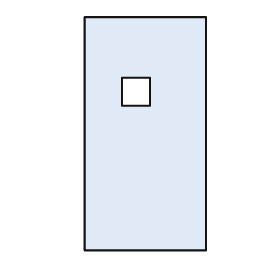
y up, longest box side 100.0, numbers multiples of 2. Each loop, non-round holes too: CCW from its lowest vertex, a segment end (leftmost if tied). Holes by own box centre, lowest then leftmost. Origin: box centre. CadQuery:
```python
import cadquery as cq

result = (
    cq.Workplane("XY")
    .moveTo(-26.0, -50.0)
    .lineTo(26.0, -50.0)
    .lineTo(26.0, 50.0)
    .lineTo(-26.0, 50.0)
    .close()
    .moveTo(-10.0, 12.0)
    .lineTo(2.0, 12.0)
    .lineTo(2.0, 24.0)
    .lineTo(-10.0, 24.0)
    .close()
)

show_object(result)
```